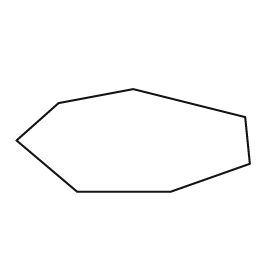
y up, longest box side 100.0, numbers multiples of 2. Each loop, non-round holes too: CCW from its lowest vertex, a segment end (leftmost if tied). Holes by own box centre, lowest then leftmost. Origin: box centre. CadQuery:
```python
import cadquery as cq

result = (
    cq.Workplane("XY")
    .moveTo(-24.0, -22.0)
    .lineTo(16.0, -22.0)
    .lineTo(50.0, -10.0)
    .lineTo(48.0, 10.0)
    .lineTo(0.0, 22.0)
    .lineTo(-32.0, 16.0)
    .lineTo(-50.0, 0.0)
    .close()
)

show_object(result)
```